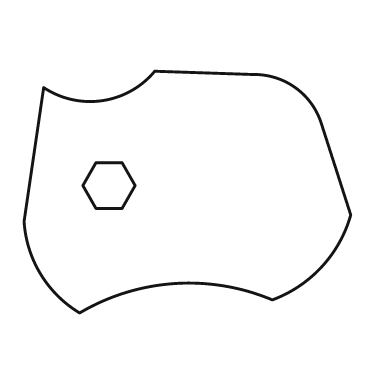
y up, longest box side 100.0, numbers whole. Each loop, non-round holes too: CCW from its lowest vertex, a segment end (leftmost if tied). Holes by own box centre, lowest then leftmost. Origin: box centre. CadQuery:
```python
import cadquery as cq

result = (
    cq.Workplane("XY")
    .moveTo(-33.0, -37.0)
    .threePointArc((-4.0, -28.0), (26.0, -33.0))
    .threePointArc((41.0, -23.0), (50.0, -7.0))
    .lineTo(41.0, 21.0)
    .threePointArc((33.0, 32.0), (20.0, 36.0))
    .lineTo(-10.0, 37.0)
    .threePointArc((-26.0, 28.0), (-44.0, 32.0))
    .lineTo(-50.0, -9.0)
    .threePointArc((-45.0, -25.0), (-33.0, -37.0))
    .close()
    .moveTo(-28.0, -5.0)
    .lineTo(-20.0, -5.0)
    .lineTo(-16.0, 2.0)
    .lineTo(-20.0, 9.0)
    .lineTo(-28.0, 9.0)
    .lineTo(-32.0, 2.0)
    .close()
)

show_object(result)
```